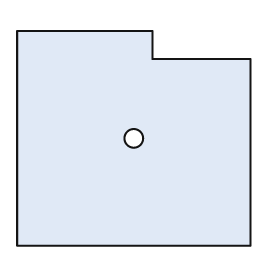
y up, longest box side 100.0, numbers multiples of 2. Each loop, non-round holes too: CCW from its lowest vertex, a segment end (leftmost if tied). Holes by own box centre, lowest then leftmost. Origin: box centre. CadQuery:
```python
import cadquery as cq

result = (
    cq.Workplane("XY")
    .moveTo(-50.0, -46.0)
    .lineTo(50.0, -46.0)
    .lineTo(50.0, 34.0)
    .lineTo(8.0, 34.0)
    .lineTo(8.0, 46.0)
    .lineTo(-50.0, 46.0)
    .close()
    .moveTo(0.0, 0.0)
    .circle(4.0)
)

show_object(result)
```